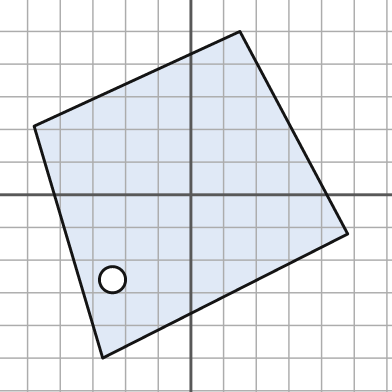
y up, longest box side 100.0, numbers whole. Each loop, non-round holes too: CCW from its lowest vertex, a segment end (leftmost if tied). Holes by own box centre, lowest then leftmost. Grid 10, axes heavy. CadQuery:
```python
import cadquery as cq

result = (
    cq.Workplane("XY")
    .moveTo(-27.0, -50.0)
    .lineTo(48.0, -12.0)
    .lineTo(15.0, 50.0)
    .lineTo(-48.0, 21.0)
    .close()
    .moveTo(-24.0, -26.0)
    .circle(4.0)
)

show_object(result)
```